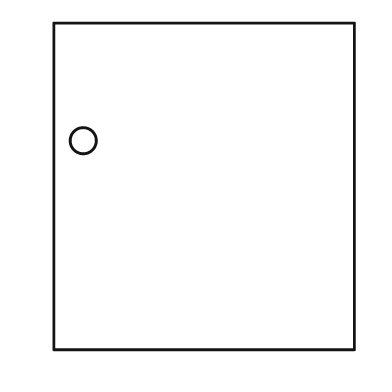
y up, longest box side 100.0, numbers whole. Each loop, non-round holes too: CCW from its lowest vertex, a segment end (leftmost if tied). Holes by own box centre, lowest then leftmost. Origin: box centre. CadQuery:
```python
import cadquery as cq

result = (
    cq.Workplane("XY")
    .moveTo(-46.0, -50.0)
    .lineTo(46.0, -50.0)
    .lineTo(46.0, 50.0)
    .lineTo(-46.0, 50.0)
    .close()
    .moveTo(-37.0, 14.0)
    .circle(4.0)
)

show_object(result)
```